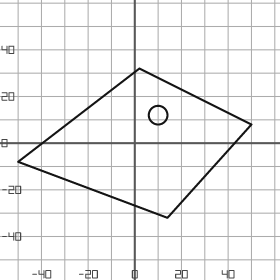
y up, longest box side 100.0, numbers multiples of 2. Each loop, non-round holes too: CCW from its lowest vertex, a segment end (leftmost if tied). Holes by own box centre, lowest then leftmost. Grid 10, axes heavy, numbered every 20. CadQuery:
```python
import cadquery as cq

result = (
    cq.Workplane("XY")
    .moveTo(14.0, -32.0)
    .lineTo(50.0, 8.0)
    .lineTo(2.0, 32.0)
    .lineTo(-50.0, -8.0)
    .close()
    .moveTo(10.0, 12.0)
    .circle(4.0)
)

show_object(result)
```